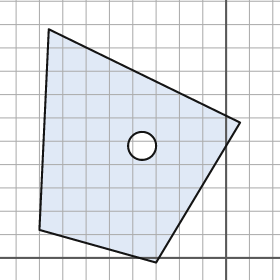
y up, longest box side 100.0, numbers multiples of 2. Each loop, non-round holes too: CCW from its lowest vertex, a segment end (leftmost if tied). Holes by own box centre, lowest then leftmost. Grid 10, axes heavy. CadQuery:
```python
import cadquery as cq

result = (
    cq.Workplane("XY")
    .moveTo(-30.0, -2.0)
    .lineTo(6.0, 58.0)
    .lineTo(-76.0, 98.0)
    .lineTo(-80.0, 12.0)
    .close()
    .moveTo(-36.0, 48.0)
    .circle(6.0)
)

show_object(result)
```